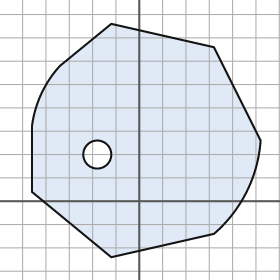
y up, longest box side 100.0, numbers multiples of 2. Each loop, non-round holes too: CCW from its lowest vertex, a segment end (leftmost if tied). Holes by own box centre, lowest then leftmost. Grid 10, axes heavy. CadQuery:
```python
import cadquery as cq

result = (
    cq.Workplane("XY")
    .moveTo(-12.0, -24.0)
    .lineTo(32.0, -14.0)
    .threePointArc((46.0, 4.0), (52.0, 26.0))
    .lineTo(32.0, 66.0)
    .lineTo(-12.0, 76.0)
    .lineTo(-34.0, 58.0)
    .threePointArc((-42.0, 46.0), (-46.0, 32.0))
    .lineTo(-46.0, 4.0)
    .close()
    .moveTo(-18.0, 20.0)
    .circle(6.0)
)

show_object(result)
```